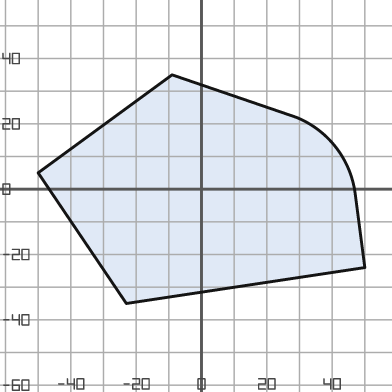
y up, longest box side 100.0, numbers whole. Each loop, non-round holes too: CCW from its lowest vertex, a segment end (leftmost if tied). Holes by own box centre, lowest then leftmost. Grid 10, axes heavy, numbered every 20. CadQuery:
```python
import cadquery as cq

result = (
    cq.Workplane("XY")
    .moveTo(-23.0, -35.0)
    .lineTo(50.0, -24.0)
    .lineTo(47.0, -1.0)
    .threePointArc((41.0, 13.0), (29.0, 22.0))
    .lineTo(-9.0, 35.0)
    .lineTo(-50.0, 5.0)
    .close()
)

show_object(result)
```